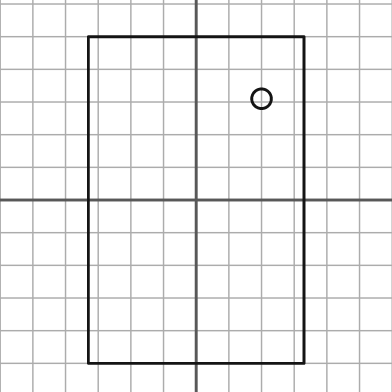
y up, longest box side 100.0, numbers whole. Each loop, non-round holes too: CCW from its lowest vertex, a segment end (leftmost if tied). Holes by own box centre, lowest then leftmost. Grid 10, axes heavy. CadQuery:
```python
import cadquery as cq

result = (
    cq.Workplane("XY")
    .moveTo(-33.0, -50.0)
    .lineTo(33.0, -50.0)
    .lineTo(33.0, 50.0)
    .lineTo(-33.0, 50.0)
    .close()
    .moveTo(20.0, 31.0)
    .circle(3.0)
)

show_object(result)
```